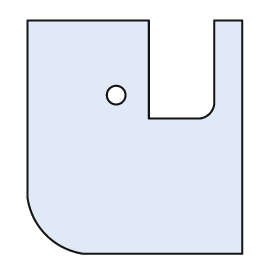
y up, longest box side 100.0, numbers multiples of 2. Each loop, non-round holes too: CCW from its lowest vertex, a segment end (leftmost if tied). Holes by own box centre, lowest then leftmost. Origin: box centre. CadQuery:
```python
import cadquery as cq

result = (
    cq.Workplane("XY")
    .moveTo(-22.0, -50.0)
    .lineTo(46.0, -50.0)
    .lineTo(46.0, 50.0)
    .lineTo(34.0, 50.0)
    .lineTo(34.0, 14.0)
    .threePointArc((32.0, 10.0), (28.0, 8.0))
    .lineTo(6.0, 8.0)
    .lineTo(6.0, 50.0)
    .lineTo(-46.0, 50.0)
    .lineTo(-46.0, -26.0)
    .threePointArc((-38.0, -42.0), (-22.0, -50.0))
    .close()
    .moveTo(-8.0, 18.0)
    .circle(4.0)
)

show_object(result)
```